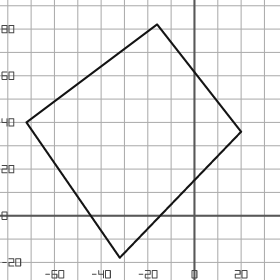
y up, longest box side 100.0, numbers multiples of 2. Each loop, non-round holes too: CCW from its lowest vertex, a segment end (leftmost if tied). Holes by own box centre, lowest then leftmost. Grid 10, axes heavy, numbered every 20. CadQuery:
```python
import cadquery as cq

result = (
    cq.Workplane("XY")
    .moveTo(-32.0, -18.0)
    .lineTo(20.0, 36.0)
    .lineTo(-16.0, 82.0)
    .lineTo(-72.0, 40.0)
    .close()
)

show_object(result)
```